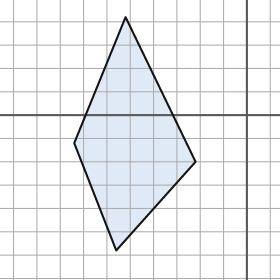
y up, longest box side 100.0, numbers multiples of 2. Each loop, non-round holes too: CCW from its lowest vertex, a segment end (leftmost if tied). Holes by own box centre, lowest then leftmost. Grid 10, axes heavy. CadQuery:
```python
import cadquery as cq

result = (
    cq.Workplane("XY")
    .moveTo(-56.0, -58.0)
    .lineTo(-22.0, -20.0)
    .lineTo(-52.0, 42.0)
    .lineTo(-74.0, -12.0)
    .close()
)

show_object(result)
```